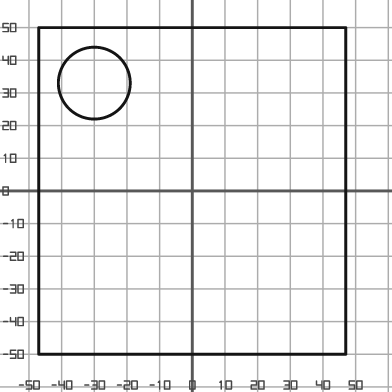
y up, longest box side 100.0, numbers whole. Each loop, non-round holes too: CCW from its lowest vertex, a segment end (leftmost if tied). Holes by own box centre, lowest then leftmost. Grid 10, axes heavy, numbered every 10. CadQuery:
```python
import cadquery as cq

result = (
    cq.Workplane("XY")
    .moveTo(-47.0, -50.0)
    .lineTo(47.0, -50.0)
    .lineTo(47.0, 50.0)
    .lineTo(-47.0, 50.0)
    .close()
    .moveTo(-30.0, 33.0)
    .circle(11.0)
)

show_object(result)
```